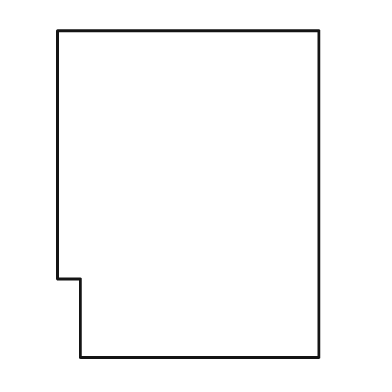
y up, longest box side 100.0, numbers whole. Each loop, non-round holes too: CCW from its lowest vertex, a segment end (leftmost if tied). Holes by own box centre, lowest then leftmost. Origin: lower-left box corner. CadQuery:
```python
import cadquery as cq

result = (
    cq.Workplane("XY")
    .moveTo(7.0, 0.0)
    .lineTo(80.0, 0.0)
    .lineTo(80.0, 100.0)
    .lineTo(0.0, 100.0)
    .lineTo(0.0, 24.0)
    .lineTo(7.0, 24.0)
    .close()
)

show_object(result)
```